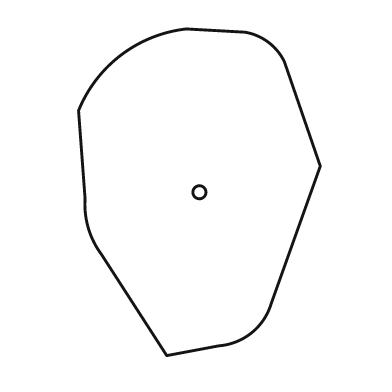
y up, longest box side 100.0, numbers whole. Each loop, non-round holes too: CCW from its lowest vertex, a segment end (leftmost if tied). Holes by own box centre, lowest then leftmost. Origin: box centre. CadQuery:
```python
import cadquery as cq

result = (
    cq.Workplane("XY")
    .moveTo(-10.0, -50.0)
    .lineTo(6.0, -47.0)
    .threePointArc((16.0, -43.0), (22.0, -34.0))
    .lineTo(37.0, 8.0)
    .lineTo(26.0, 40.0)
    .threePointArc((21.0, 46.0), (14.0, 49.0))
    .lineTo(-4.0, 50.0)
    .threePointArc((-24.0, 42.0), (-37.0, 25.0))
    .lineTo(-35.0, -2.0)
    .threePointArc((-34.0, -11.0), (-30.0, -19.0))
    .close()
    .moveTo(0.0, 0.0)
    .circle(2.0)
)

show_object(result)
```